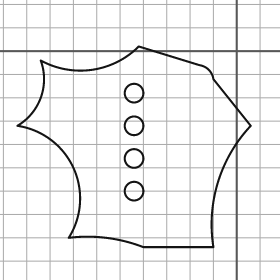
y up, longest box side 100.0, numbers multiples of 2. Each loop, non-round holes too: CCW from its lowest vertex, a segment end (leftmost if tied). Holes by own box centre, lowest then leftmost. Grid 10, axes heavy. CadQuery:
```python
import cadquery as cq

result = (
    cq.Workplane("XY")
    .moveTo(-40.0, -84.0)
    .lineTo(-10.0, -84.0)
    .threePointArc((-8.0, -56.0), (6.0, -32.0))
    .lineTo(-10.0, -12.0)
    .threePointArc((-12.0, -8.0), (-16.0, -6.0))
    .lineTo(-42.0, 2.0)
    .threePointArc((-62.0, -8.0), (-84.0, -4.0))
    .threePointArc((-84.0, -20.0), (-94.0, -32.0))
    .threePointArc((-70.0, -50.0), (-72.0, -80.0))
    .threePointArc((-56.0, -80.0), (-40.0, -84.0))
    .close()
    .moveTo(-44.0, -60.0)
    .circle(4.0)
    .moveTo(-44.0, -46.0)
    .circle(4.0)
    .moveTo(-44.0, -32.0)
    .circle(4.0)
    .moveTo(-44.0, -18.0)
    .circle(4.0)
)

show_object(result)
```